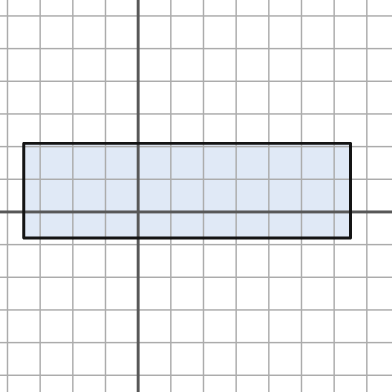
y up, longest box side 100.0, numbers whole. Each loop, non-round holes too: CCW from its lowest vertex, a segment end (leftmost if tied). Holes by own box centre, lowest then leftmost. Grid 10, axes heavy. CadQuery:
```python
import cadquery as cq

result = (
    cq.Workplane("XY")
    .moveTo(-35.0, -8.0)
    .lineTo(65.0, -8.0)
    .lineTo(65.0, 21.0)
    .lineTo(-35.0, 21.0)
    .close()
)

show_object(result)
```